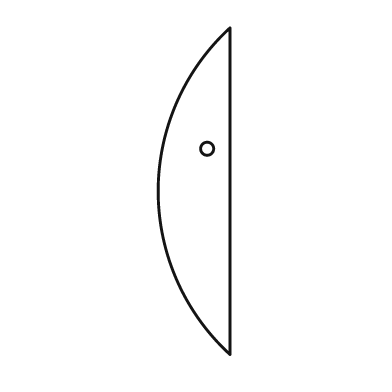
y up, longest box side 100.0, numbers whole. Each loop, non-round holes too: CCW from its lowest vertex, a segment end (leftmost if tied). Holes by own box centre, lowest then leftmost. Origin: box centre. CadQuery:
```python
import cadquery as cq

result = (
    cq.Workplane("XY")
    .moveTo(11.0, -50.0)
    .lineTo(11.0, 50.0)
    .threePointArc((-11.0, 0.0), (11.0, -50.0))
    .close()
    .moveTo(4.0, 13.0)
    .circle(2.0)
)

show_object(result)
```